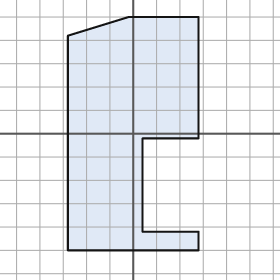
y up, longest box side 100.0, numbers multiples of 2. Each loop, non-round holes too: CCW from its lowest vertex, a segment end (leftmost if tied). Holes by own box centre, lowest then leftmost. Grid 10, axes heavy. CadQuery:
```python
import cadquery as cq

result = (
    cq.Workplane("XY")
    .moveTo(-28.0, -50.0)
    .lineTo(28.0, -50.0)
    .lineTo(28.0, -42.0)
    .lineTo(4.0, -42.0)
    .lineTo(4.0, -2.0)
    .lineTo(28.0, -2.0)
    .lineTo(28.0, 50.0)
    .lineTo(-2.0, 50.0)
    .lineTo(-28.0, 42.0)
    .close()
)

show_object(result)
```